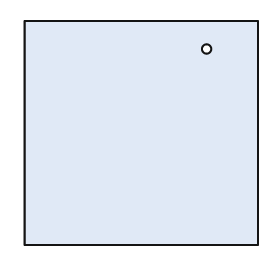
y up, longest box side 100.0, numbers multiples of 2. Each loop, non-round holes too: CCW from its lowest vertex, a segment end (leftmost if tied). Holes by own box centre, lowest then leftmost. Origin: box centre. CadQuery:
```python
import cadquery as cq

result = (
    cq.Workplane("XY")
    .moveTo(-50.0, -48.0)
    .lineTo(50.0, -48.0)
    .lineTo(50.0, 48.0)
    .lineTo(-50.0, 48.0)
    .close()
    .moveTo(28.0, 36.0)
    .circle(2.0)
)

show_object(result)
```